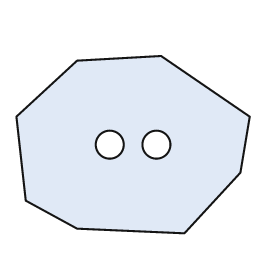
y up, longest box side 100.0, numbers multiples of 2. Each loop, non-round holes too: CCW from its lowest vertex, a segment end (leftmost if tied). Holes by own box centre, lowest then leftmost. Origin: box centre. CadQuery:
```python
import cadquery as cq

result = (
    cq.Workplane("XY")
    .moveTo(22.0, -38.0)
    .lineTo(46.0, -12.0)
    .lineTo(50.0, 12.0)
    .lineTo(12.0, 38.0)
    .lineTo(-24.0, 36.0)
    .lineTo(-50.0, 12.0)
    .lineTo(-46.0, -24.0)
    .lineTo(-24.0, -36.0)
    .close()
    .moveTo(-10.0, 0.0)
    .circle(6.0)
    .moveTo(10.0, 0.0)
    .circle(6.0)
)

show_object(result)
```